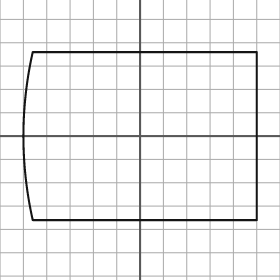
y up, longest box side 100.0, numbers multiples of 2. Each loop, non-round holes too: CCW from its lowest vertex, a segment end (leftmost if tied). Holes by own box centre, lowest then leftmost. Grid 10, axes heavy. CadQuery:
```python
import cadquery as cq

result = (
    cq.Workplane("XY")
    .moveTo(-46.0, -36.0)
    .lineTo(50.0, -36.0)
    .lineTo(50.0, 36.0)
    .lineTo(-46.0, 36.0)
    .threePointArc((-50.0, 0.0), (-46.0, -36.0))
    .close()
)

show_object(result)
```